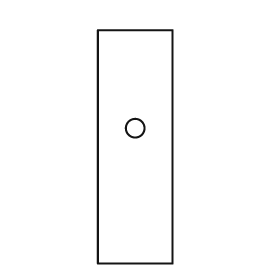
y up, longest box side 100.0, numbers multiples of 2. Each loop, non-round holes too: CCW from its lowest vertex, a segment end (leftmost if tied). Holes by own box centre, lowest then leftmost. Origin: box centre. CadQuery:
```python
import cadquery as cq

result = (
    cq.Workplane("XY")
    .moveTo(-16.0, -50.0)
    .lineTo(16.0, -50.0)
    .lineTo(16.0, 50.0)
    .lineTo(-16.0, 50.0)
    .close()
    .moveTo(0.0, 8.0)
    .circle(4.0)
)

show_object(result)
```